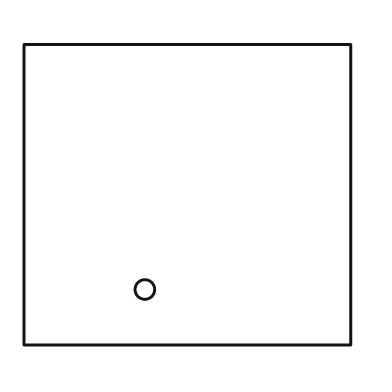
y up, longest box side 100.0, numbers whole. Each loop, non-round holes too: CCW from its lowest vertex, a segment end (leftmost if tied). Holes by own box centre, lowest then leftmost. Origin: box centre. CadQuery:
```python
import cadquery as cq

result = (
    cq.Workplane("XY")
    .moveTo(-50.0, -46.0)
    .lineTo(50.0, -46.0)
    .lineTo(50.0, 46.0)
    .lineTo(-50.0, 46.0)
    .close()
    .moveTo(-13.0, -29.0)
    .circle(3.0)
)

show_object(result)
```